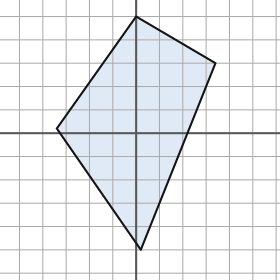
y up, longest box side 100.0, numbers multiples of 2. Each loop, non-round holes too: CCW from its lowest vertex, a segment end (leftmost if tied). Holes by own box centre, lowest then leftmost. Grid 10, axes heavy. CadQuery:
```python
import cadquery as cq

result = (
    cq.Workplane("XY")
    .moveTo(2.0, -50.0)
    .lineTo(34.0, 30.0)
    .lineTo(0.0, 50.0)
    .lineTo(-34.0, 2.0)
    .close()
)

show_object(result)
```